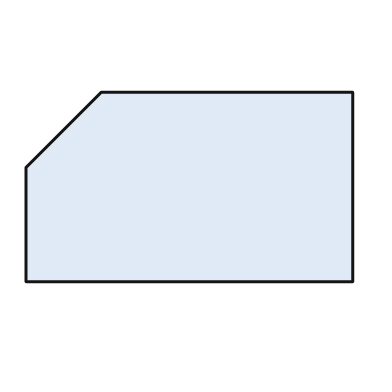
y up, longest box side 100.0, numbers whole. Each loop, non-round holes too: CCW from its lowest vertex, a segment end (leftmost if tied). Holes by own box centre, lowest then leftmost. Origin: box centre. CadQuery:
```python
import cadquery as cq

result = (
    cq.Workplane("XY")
    .moveTo(-50.0, -29.0)
    .lineTo(50.0, -29.0)
    .lineTo(50.0, 29.0)
    .lineTo(-27.0, 29.0)
    .lineTo(-50.0, 6.0)
    .close()
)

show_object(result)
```